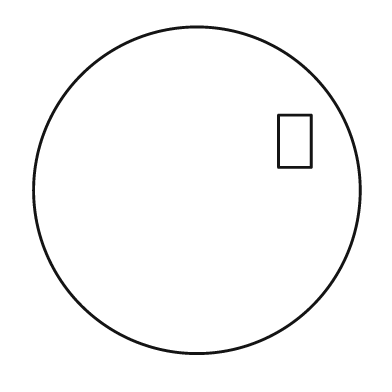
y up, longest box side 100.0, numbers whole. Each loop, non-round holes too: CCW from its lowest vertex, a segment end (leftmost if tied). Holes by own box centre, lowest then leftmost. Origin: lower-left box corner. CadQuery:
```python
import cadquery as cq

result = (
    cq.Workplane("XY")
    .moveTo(50.0, 50.0)
    .circle(50.0)
    .moveTo(75.0, 57.0)
    .lineTo(85.0, 57.0)
    .lineTo(85.0, 73.0)
    .lineTo(75.0, 73.0)
    .close()
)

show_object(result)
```